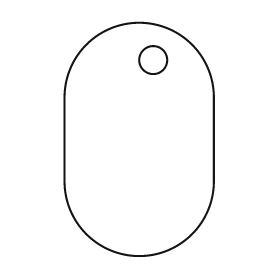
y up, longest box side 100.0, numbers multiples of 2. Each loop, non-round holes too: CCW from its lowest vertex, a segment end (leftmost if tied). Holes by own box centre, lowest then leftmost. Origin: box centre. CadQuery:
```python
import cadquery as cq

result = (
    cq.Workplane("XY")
    .moveTo(-32.0, -18.0)
    .threePointArc((0.0, -50.0), (32.0, -18.0))
    .lineTo(32.0, 18.0)
    .threePointArc((0.0, 50.0), (-32.0, 18.0))
    .close()
    .moveTo(6.0, 34.0)
    .circle(6.0)
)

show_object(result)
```